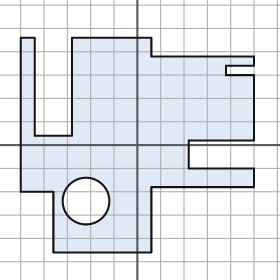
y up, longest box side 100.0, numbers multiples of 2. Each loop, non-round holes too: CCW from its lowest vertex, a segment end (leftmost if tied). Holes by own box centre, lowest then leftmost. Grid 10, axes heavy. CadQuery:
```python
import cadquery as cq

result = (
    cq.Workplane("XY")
    .moveTo(-36.0, -46.0)
    .lineTo(6.0, -46.0)
    .lineTo(6.0, -18.0)
    .lineTo(50.0, -18.0)
    .lineTo(50.0, -10.0)
    .lineTo(22.0, -10.0)
    .lineTo(22.0, 2.0)
    .lineTo(50.0, 2.0)
    .lineTo(50.0, 30.0)
    .lineTo(38.0, 30.0)
    .lineTo(38.0, 34.0)
    .lineTo(50.0, 34.0)
    .lineTo(50.0, 38.0)
    .lineTo(6.0, 38.0)
    .lineTo(6.0, 46.0)
    .lineTo(-28.0, 46.0)
    .lineTo(-28.0, 4.0)
    .lineTo(-44.0, 4.0)
    .lineTo(-44.0, 46.0)
    .lineTo(-50.0, 46.0)
    .lineTo(-50.0, -20.0)
    .lineTo(-36.0, -20.0)
    .close()
    .moveTo(-22.0, -24.0)
    .circle(10.0)
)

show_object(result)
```